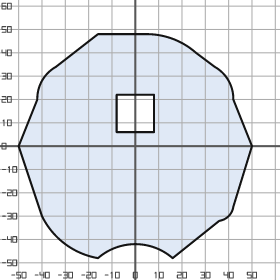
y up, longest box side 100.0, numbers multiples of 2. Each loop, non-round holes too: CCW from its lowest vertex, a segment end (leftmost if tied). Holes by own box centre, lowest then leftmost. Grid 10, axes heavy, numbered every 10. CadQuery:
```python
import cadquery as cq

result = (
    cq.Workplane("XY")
    .moveTo(-16.0, -48.0)
    .threePointArc((0.0, -42.0), (16.0, -48.0))
    .lineTo(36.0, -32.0)
    .threePointArc((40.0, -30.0), (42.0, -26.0))
    .lineTo(50.0, 0.0)
    .lineTo(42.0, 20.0)
    .threePointArc((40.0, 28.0), (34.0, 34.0))
    .lineTo(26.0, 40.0)
    .threePointArc((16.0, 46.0), (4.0, 48.0))
    .lineTo(-16.0, 48.0)
    .lineTo(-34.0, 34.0)
    .threePointArc((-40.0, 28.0), (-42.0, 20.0))
    .lineTo(-50.0, 0.0)
    .lineTo(-40.0, -30.0)
    .threePointArc((-30.0, -42.0), (-16.0, -48.0))
    .close()
    .moveTo(-8.0, 6.0)
    .lineTo(8.0, 6.0)
    .lineTo(8.0, 22.0)
    .lineTo(-8.0, 22.0)
    .close()
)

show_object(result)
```